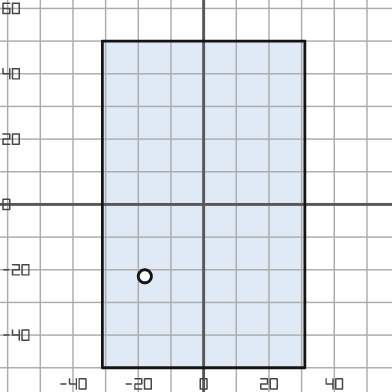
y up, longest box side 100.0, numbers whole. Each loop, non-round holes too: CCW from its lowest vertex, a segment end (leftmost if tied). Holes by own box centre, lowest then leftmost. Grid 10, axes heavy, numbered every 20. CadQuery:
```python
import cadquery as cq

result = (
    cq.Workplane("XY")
    .moveTo(-31.0, -50.0)
    .lineTo(31.0, -50.0)
    .lineTo(31.0, 50.0)
    .lineTo(-31.0, 50.0)
    .close()
    .moveTo(-18.0, -22.0)
    .circle(2.0)
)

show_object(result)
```